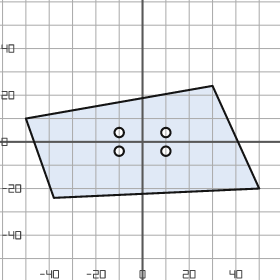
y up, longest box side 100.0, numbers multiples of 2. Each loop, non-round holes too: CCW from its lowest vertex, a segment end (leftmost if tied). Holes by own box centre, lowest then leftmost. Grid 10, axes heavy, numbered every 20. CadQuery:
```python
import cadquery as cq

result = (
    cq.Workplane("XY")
    .moveTo(-38.0, -24.0)
    .lineTo(50.0, -20.0)
    .lineTo(30.0, 24.0)
    .lineTo(-50.0, 10.0)
    .close()
    .moveTo(-10.0, -4.0)
    .circle(2.0)
    .moveTo(10.0, -4.0)
    .circle(2.0)
    .moveTo(-10.0, 4.0)
    .circle(2.0)
    .moveTo(10.0, 4.0)
    .circle(2.0)
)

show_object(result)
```